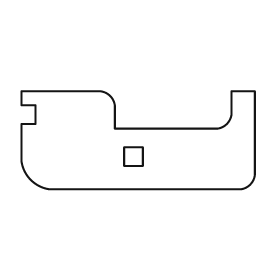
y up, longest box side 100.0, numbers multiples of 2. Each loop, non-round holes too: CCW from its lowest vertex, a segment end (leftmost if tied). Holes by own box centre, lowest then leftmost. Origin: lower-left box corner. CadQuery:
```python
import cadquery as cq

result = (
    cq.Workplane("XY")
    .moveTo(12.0, 0.0)
    .lineTo(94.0, 0.0)
    .threePointArc((98.0, 2.0), (100.0, 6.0))
    .lineTo(100.0, 42.0)
    .lineTo(90.0, 42.0)
    .lineTo(90.0, 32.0)
    .threePointArc((88.0, 28.0), (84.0, 26.0))
    .lineTo(40.0, 26.0)
    .lineTo(40.0, 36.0)
    .threePointArc((38.0, 40.0), (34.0, 42.0))
    .lineTo(0.0, 42.0)
    .lineTo(0.0, 36.0)
    .lineTo(6.0, 36.0)
    .lineTo(6.0, 28.0)
    .lineTo(0.0, 28.0)
    .lineTo(0.0, 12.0)
    .threePointArc((4.0, 4.0), (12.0, 0.0))
    .close()
    .moveTo(44.0, 10.0)
    .lineTo(52.0, 10.0)
    .lineTo(52.0, 18.0)
    .lineTo(44.0, 18.0)
    .close()
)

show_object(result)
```